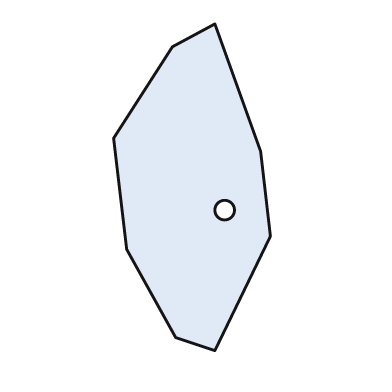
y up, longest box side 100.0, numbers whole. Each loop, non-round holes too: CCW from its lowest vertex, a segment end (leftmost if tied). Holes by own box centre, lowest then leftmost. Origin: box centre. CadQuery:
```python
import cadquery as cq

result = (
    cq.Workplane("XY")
    .moveTo(7.0, -50.0)
    .lineTo(24.0, -15.0)
    .lineTo(21.0, 11.0)
    .lineTo(7.0, 50.0)
    .lineTo(-6.0, 43.0)
    .lineTo(-24.0, 15.0)
    .lineTo(-20.0, -19.0)
    .lineTo(-5.0, -46.0)
    .close()
    .moveTo(10.0, -7.0)
    .circle(3.0)
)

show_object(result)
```